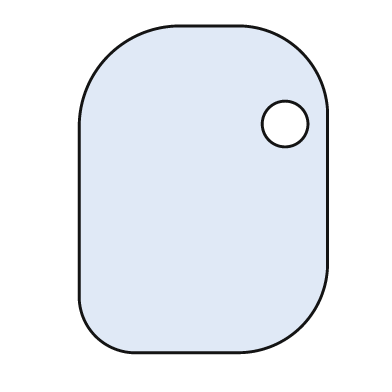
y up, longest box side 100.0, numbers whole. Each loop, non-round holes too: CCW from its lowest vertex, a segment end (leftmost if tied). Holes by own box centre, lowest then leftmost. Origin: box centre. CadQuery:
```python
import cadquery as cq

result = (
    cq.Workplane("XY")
    .moveTo(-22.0, -50.0)
    .lineTo(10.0, -50.0)
    .threePointArc((30.0, -42.0), (38.0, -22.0))
    .lineTo(38.0, 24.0)
    .threePointArc((30.0, 42.0), (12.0, 50.0))
    .lineTo(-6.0, 50.0)
    .threePointArc((-29.0, 41.0), (-38.0, 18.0))
    .lineTo(-38.0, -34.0)
    .threePointArc((-33.0, -45.0), (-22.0, -50.0))
    .close()
    .moveTo(25.0, 20.0)
    .circle(7.0)
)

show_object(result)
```